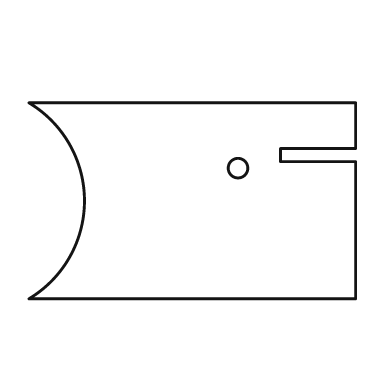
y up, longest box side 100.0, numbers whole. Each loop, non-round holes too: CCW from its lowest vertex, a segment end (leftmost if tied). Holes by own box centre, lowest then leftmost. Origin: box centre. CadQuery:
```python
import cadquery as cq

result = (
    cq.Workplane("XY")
    .moveTo(-50.0, -30.0)
    .lineTo(50.0, -30.0)
    .lineTo(50.0, 12.0)
    .lineTo(27.0, 12.0)
    .lineTo(27.0, 16.0)
    .lineTo(50.0, 16.0)
    .lineTo(50.0, 30.0)
    .lineTo(-50.0, 30.0)
    .threePointArc((-33.0, 0.0), (-50.0, -30.0))
    .close()
    .moveTo(14.0, 10.0)
    .circle(3.0)
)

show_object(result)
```